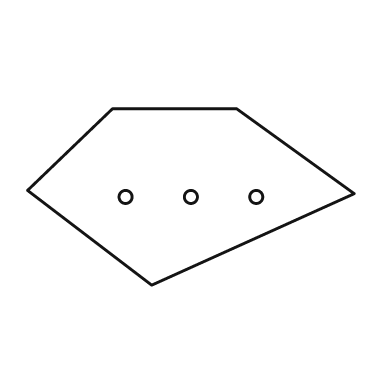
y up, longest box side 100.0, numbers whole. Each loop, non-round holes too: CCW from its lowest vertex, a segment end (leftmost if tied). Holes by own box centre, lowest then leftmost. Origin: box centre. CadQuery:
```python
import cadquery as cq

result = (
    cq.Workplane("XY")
    .moveTo(-12.0, -27.0)
    .lineTo(50.0, 1.0)
    .lineTo(14.0, 27.0)
    .lineTo(-24.0, 27.0)
    .lineTo(-50.0, 2.0)
    .close()
    .moveTo(-20.0, 0.0)
    .circle(2.0)
    .moveTo(0.0, 0.0)
    .circle(2.0)
    .moveTo(20.0, 0.0)
    .circle(2.0)
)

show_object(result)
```